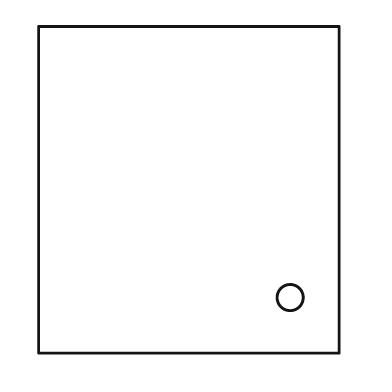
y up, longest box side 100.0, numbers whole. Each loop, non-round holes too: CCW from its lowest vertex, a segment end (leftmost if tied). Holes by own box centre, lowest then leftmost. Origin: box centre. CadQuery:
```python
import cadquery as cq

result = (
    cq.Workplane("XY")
    .moveTo(-46.0, -50.0)
    .lineTo(46.0, -50.0)
    .lineTo(46.0, 50.0)
    .lineTo(-46.0, 50.0)
    .close()
    .moveTo(31.0, -33.0)
    .circle(4.0)
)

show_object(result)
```